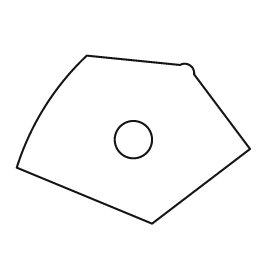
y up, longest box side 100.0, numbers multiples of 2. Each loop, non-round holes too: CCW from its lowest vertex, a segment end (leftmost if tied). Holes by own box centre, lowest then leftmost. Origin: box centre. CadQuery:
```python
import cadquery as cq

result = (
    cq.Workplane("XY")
    .moveTo(8.0, -36.0)
    .lineTo(50.0, -4.0)
    .lineTo(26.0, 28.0)
    .threePointArc((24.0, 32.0), (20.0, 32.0))
    .lineTo(-20.0, 36.0)
    .threePointArc((-38.0, 14.0), (-50.0, -12.0))
    .close()
    .moveTo(0.0, 0.0)
    .circle(8.0)
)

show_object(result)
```